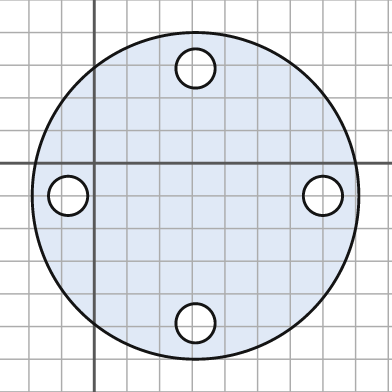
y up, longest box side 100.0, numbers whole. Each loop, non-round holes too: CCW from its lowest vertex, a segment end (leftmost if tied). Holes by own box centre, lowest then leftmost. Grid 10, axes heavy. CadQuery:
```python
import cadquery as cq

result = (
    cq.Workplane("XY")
    .moveTo(31.0, -10.0)
    .circle(50.0)
    .moveTo(31.0, -49.0)
    .circle(6.0)
    .moveTo(-8.0, -10.0)
    .circle(6.0)
    .moveTo(70.0, -10.0)
    .circle(6.0)
    .moveTo(31.0, 29.0)
    .circle(6.0)
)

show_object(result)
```